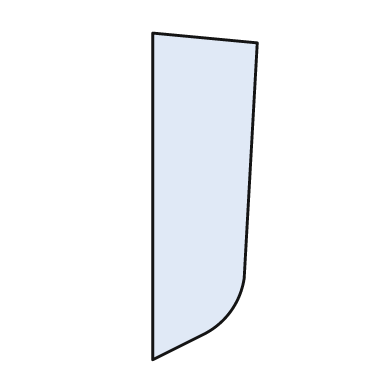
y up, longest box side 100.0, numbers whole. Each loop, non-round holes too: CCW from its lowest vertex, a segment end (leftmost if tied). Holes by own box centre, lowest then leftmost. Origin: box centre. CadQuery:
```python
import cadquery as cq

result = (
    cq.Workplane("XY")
    .moveTo(-16.0, -50.0)
    .lineTo(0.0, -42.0)
    .threePointArc((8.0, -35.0), (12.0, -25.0))
    .lineTo(16.0, 47.0)
    .lineTo(-16.0, 50.0)
    .close()
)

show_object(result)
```